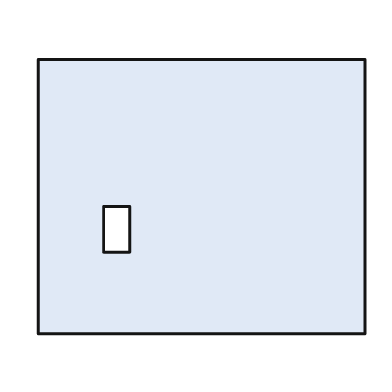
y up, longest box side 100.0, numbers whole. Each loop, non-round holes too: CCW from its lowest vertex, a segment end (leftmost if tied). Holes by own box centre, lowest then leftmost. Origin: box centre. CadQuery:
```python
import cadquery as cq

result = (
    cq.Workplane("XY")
    .moveTo(-50.0, -42.0)
    .lineTo(50.0, -42.0)
    .lineTo(50.0, 42.0)
    .lineTo(-50.0, 42.0)
    .close()
    .moveTo(-30.0, -17.0)
    .lineTo(-22.0, -17.0)
    .lineTo(-22.0, -3.0)
    .lineTo(-30.0, -3.0)
    .close()
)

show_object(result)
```